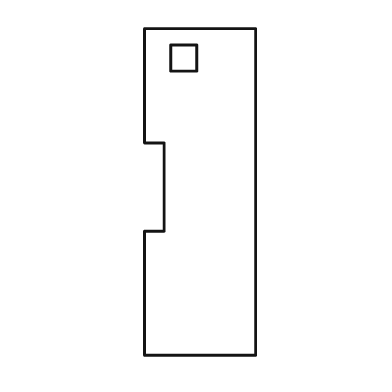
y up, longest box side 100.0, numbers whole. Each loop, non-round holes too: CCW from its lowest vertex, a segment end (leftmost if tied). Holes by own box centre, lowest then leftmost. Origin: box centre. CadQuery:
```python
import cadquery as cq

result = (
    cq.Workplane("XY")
    .moveTo(-17.0, -50.0)
    .lineTo(17.0, -50.0)
    .lineTo(17.0, 50.0)
    .lineTo(-17.0, 50.0)
    .lineTo(-17.0, 15.0)
    .lineTo(-11.0, 15.0)
    .lineTo(-11.0, -12.0)
    .lineTo(-17.0, -12.0)
    .close()
    .moveTo(-9.0, 37.0)
    .lineTo(-1.0, 37.0)
    .lineTo(-1.0, 45.0)
    .lineTo(-9.0, 45.0)
    .close()
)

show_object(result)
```